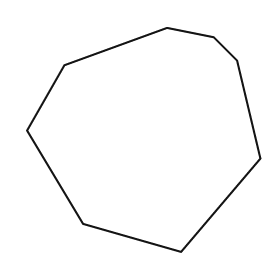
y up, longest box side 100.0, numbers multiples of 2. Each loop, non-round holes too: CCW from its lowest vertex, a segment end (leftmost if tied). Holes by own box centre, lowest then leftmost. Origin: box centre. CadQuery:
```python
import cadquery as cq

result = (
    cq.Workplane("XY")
    .moveTo(16.0, -48.0)
    .lineTo(50.0, -8.0)
    .lineTo(40.0, 34.0)
    .lineTo(30.0, 44.0)
    .lineTo(10.0, 48.0)
    .lineTo(-34.0, 32.0)
    .lineTo(-50.0, 4.0)
    .lineTo(-26.0, -36.0)
    .close()
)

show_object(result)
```